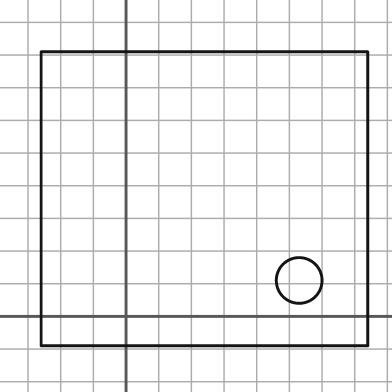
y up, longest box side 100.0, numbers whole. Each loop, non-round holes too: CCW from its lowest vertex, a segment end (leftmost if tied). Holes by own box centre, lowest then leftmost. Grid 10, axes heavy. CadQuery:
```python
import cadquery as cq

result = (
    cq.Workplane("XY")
    .moveTo(-26.0, -9.0)
    .lineTo(74.0, -9.0)
    .lineTo(74.0, 81.0)
    .lineTo(-26.0, 81.0)
    .close()
    .moveTo(53.0, 11.0)
    .circle(7.0)
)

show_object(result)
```